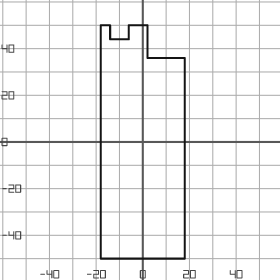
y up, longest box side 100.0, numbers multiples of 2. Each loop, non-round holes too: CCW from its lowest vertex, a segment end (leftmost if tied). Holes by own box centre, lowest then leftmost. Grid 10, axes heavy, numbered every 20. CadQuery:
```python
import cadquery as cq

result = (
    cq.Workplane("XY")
    .moveTo(-18.0, -50.0)
    .lineTo(18.0, -50.0)
    .lineTo(18.0, 36.0)
    .lineTo(2.0, 36.0)
    .lineTo(2.0, 50.0)
    .lineTo(-6.0, 50.0)
    .lineTo(-6.0, 44.0)
    .lineTo(-14.0, 44.0)
    .lineTo(-14.0, 50.0)
    .lineTo(-18.0, 50.0)
    .close()
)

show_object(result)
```